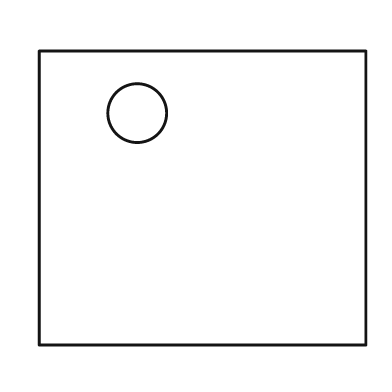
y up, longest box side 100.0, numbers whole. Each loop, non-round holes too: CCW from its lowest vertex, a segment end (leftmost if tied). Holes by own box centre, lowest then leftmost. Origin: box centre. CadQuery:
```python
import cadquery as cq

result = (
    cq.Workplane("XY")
    .moveTo(-50.0, -45.0)
    .lineTo(50.0, -45.0)
    .lineTo(50.0, 45.0)
    .lineTo(-50.0, 45.0)
    .close()
    .moveTo(-20.0, 26.0)
    .circle(9.0)
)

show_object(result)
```